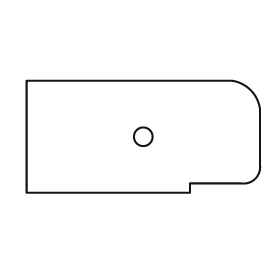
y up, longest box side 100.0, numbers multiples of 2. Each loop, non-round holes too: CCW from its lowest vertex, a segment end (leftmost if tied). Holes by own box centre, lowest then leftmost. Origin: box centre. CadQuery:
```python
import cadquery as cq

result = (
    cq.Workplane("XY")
    .moveTo(-50.0, -24.0)
    .lineTo(20.0, -24.0)
    .lineTo(20.0, -20.0)
    .lineTo(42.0, -20.0)
    .threePointArc((48.0, -18.0), (50.0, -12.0))
    .lineTo(50.0, 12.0)
    .threePointArc((46.0, 20.0), (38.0, 24.0))
    .lineTo(-50.0, 24.0)
    .close()
    .moveTo(0.0, 0.0)
    .circle(4.0)
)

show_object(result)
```